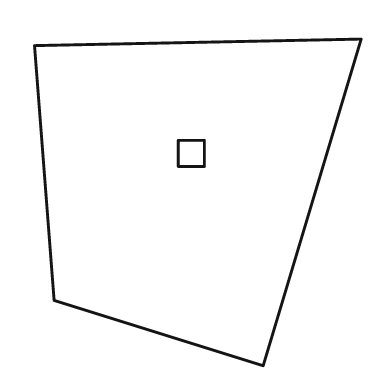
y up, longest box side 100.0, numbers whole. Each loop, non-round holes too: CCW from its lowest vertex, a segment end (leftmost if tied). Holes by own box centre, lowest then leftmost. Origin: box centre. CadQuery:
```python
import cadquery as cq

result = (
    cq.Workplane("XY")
    .moveTo(20.0, -50.0)
    .lineTo(50.0, 50.0)
    .lineTo(-50.0, 48.0)
    .lineTo(-44.0, -30.0)
    .close()
    .moveTo(-6.0, 11.0)
    .lineTo(2.0, 11.0)
    .lineTo(2.0, 19.0)
    .lineTo(-6.0, 19.0)
    .close()
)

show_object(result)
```